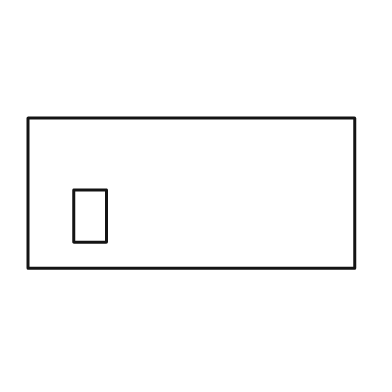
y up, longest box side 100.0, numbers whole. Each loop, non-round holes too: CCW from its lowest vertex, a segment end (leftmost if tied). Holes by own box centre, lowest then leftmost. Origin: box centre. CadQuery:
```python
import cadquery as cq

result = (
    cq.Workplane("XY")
    .moveTo(-50.0, -23.0)
    .lineTo(50.0, -23.0)
    .lineTo(50.0, 23.0)
    .lineTo(-50.0, 23.0)
    .close()
    .moveTo(-36.0, -15.0)
    .lineTo(-26.0, -15.0)
    .lineTo(-26.0, 1.0)
    .lineTo(-36.0, 1.0)
    .close()
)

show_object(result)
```